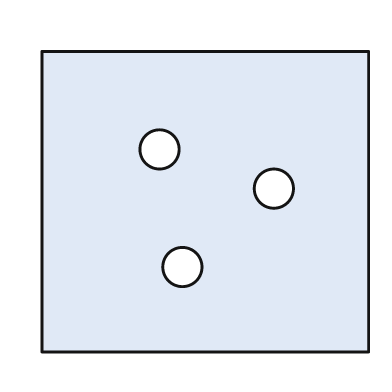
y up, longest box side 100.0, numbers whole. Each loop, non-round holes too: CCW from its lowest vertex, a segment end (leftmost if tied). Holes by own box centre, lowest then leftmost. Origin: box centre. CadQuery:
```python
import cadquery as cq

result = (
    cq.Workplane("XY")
    .moveTo(-50.0, -46.0)
    .lineTo(50.0, -46.0)
    .lineTo(50.0, 46.0)
    .lineTo(-50.0, 46.0)
    .close()
    .moveTo(-7.0, -20.0)
    .circle(6.0)
    .moveTo(21.0, 4.0)
    .circle(6.0)
    .moveTo(-14.0, 16.0)
    .circle(6.0)
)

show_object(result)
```